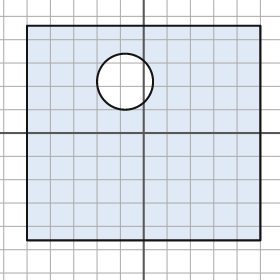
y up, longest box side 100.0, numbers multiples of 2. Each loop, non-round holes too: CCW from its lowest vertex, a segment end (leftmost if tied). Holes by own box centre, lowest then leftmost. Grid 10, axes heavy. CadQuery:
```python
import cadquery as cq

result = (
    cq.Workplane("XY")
    .moveTo(-50.0, -46.0)
    .lineTo(50.0, -46.0)
    .lineTo(50.0, 46.0)
    .lineTo(-50.0, 46.0)
    .close()
    .moveTo(-8.0, 22.0)
    .circle(12.0)
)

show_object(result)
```